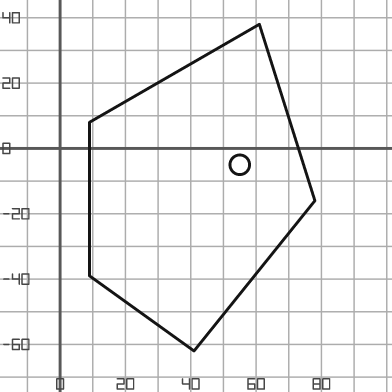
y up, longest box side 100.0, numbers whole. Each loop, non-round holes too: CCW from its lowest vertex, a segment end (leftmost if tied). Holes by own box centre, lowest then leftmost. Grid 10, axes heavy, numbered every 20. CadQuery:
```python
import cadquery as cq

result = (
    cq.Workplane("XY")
    .moveTo(41.0, -62.0)
    .lineTo(78.0, -16.0)
    .lineTo(61.0, 38.0)
    .lineTo(9.0, 8.0)
    .lineTo(9.0, -39.0)
    .close()
    .moveTo(55.0, -5.0)
    .circle(3.0)
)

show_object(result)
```